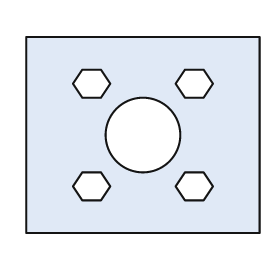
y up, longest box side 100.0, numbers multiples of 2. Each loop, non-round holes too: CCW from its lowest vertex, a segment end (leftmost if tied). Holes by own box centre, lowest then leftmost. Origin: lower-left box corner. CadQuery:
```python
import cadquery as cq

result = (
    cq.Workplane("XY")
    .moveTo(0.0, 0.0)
    .lineTo(100.0, 0.0)
    .lineTo(100.0, 84.0)
    .lineTo(0.0, 84.0)
    .close()
    .moveTo(24.0, 14.0)
    .lineTo(32.0, 14.0)
    .lineTo(36.0, 20.0)
    .lineTo(32.0, 26.0)
    .lineTo(24.0, 26.0)
    .lineTo(20.0, 20.0)
    .close()
    .moveTo(68.0, 14.0)
    .lineTo(76.0, 14.0)
    .lineTo(80.0, 20.0)
    .lineTo(76.0, 26.0)
    .lineTo(68.0, 26.0)
    .lineTo(64.0, 20.0)
    .close()
    .moveTo(50.0, 42.0)
    .circle(16.0)
    .moveTo(24.0, 58.0)
    .lineTo(32.0, 58.0)
    .lineTo(36.0, 64.0)
    .lineTo(32.0, 70.0)
    .lineTo(24.0, 70.0)
    .lineTo(20.0, 64.0)
    .close()
    .moveTo(68.0, 58.0)
    .lineTo(76.0, 58.0)
    .lineTo(80.0, 64.0)
    .lineTo(76.0, 70.0)
    .lineTo(68.0, 70.0)
    .lineTo(64.0, 64.0)
    .close()
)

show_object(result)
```